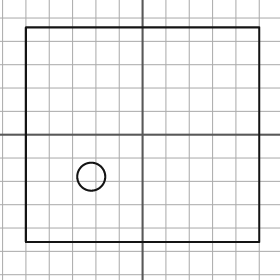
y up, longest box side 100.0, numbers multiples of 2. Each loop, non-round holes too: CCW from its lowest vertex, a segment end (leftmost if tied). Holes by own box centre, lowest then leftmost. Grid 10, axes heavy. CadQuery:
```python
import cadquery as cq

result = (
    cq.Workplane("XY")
    .moveTo(-50.0, -46.0)
    .lineTo(50.0, -46.0)
    .lineTo(50.0, 46.0)
    .lineTo(-50.0, 46.0)
    .close()
    .moveTo(-22.0, -18.0)
    .circle(6.0)
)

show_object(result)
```